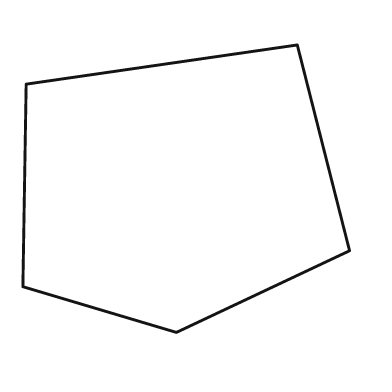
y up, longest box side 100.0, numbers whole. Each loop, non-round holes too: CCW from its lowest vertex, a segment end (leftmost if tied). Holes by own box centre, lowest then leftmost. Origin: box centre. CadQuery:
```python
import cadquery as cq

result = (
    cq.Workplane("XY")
    .moveTo(-3.0, -44.0)
    .lineTo(50.0, -19.0)
    .lineTo(34.0, 44.0)
    .lineTo(-49.0, 32.0)
    .lineTo(-50.0, -30.0)
    .close()
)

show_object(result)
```